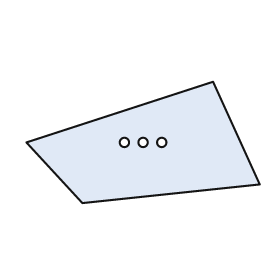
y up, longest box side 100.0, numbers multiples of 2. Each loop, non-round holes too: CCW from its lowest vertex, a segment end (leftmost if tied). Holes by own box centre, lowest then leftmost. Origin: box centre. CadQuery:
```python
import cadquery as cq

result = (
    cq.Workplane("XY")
    .moveTo(-26.0, -26.0)
    .lineTo(50.0, -18.0)
    .lineTo(30.0, 26.0)
    .lineTo(-50.0, 0.0)
    .close()
    .moveTo(-8.0, 0.0)
    .circle(2.0)
    .moveTo(0.0, 0.0)
    .circle(2.0)
    .moveTo(8.0, 0.0)
    .circle(2.0)
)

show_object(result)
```